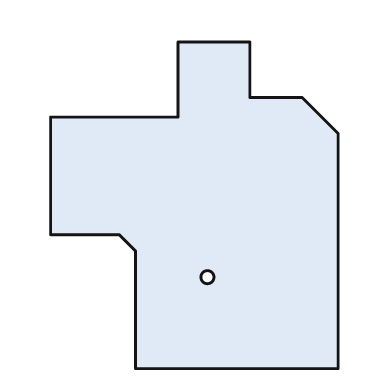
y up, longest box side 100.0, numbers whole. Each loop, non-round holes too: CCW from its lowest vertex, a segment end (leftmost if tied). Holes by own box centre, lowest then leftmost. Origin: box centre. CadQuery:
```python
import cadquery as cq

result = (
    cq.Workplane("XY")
    .moveTo(-18.0, -50.0)
    .lineTo(44.0, -50.0)
    .lineTo(44.0, 22.0)
    .lineTo(33.0, 33.0)
    .lineTo(17.0, 33.0)
    .lineTo(17.0, 50.0)
    .lineTo(-5.0, 50.0)
    .lineTo(-5.0, 27.0)
    .lineTo(-44.0, 27.0)
    .lineTo(-44.0, -9.0)
    .lineTo(-23.0, -9.0)
    .lineTo(-18.0, -14.0)
    .close()
    .moveTo(4.0, -22.0)
    .circle(2.0)
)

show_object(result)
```